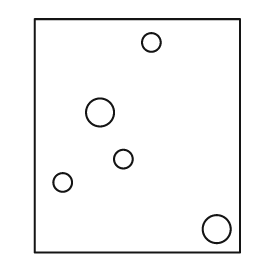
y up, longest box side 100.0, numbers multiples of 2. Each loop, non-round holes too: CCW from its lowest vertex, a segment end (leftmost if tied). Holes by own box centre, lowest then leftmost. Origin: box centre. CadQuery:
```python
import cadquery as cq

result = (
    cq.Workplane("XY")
    .moveTo(-44.0, -50.0)
    .lineTo(44.0, -50.0)
    .lineTo(44.0, 50.0)
    .lineTo(-44.0, 50.0)
    .close()
    .moveTo(34.0, -40.0)
    .circle(6.0)
    .moveTo(-32.0, -20.0)
    .circle(4.0)
    .moveTo(-6.0, -10.0)
    .circle(4.0)
    .moveTo(-16.0, 10.0)
    .circle(6.0)
    .moveTo(6.0, 40.0)
    .circle(4.0)
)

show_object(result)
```